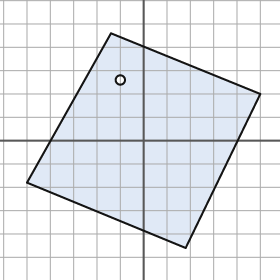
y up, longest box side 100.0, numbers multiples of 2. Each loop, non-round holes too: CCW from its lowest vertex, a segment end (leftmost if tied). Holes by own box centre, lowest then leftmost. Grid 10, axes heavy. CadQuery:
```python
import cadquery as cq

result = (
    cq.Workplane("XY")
    .moveTo(18.0, -46.0)
    .lineTo(50.0, 20.0)
    .lineTo(-14.0, 46.0)
    .lineTo(-50.0, -18.0)
    .close()
    .moveTo(-10.0, 26.0)
    .circle(2.0)
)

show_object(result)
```